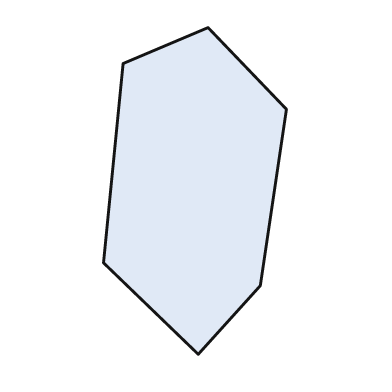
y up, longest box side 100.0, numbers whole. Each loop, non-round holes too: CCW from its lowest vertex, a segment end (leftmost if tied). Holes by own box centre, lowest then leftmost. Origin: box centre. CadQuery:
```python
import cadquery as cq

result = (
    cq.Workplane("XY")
    .moveTo(1.0, -50.0)
    .lineTo(20.0, -29.0)
    .lineTo(28.0, 25.0)
    .lineTo(4.0, 50.0)
    .lineTo(-22.0, 39.0)
    .lineTo(-28.0, -22.0)
    .close()
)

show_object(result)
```